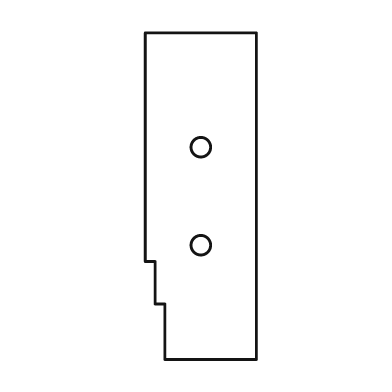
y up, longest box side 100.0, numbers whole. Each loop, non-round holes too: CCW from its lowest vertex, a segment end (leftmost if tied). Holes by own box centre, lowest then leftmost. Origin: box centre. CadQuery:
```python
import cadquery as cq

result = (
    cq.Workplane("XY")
    .moveTo(-11.0, -50.0)
    .lineTo(17.0, -50.0)
    .lineTo(17.0, 50.0)
    .lineTo(-17.0, 50.0)
    .lineTo(-17.0, -20.0)
    .lineTo(-14.0, -20.0)
    .lineTo(-14.0, -33.0)
    .lineTo(-11.0, -33.0)
    .close()
    .moveTo(0.0, -15.0)
    .circle(3.0)
    .moveTo(0.0, 15.0)
    .circle(3.0)
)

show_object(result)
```